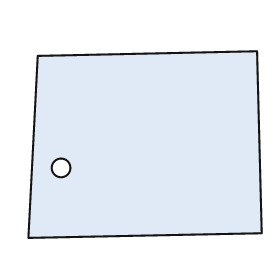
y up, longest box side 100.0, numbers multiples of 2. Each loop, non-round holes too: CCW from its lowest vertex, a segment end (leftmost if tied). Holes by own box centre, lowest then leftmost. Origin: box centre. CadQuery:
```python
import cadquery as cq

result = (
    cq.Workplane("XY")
    .moveTo(-50.0, -40.0)
    .lineTo(50.0, -38.0)
    .lineTo(48.0, 40.0)
    .lineTo(-46.0, 38.0)
    .close()
    .moveTo(-36.0, -10.0)
    .circle(4.0)
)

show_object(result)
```